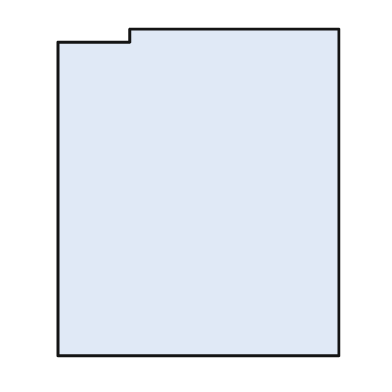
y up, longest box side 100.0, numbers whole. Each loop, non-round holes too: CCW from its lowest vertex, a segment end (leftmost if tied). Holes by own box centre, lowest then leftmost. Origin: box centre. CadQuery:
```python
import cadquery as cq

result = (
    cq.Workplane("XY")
    .moveTo(-43.0, -50.0)
    .lineTo(43.0, -50.0)
    .lineTo(43.0, 50.0)
    .lineTo(-21.0, 50.0)
    .lineTo(-21.0, 46.0)
    .lineTo(-43.0, 46.0)
    .close()
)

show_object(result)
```